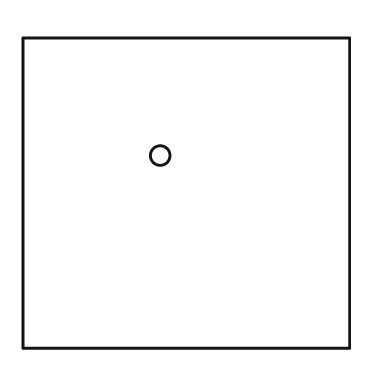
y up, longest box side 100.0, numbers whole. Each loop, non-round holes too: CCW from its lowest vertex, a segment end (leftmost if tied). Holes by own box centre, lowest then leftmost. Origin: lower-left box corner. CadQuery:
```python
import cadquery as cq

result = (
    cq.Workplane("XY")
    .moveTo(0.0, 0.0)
    .lineTo(100.0, 0.0)
    .lineTo(100.0, 95.0)
    .lineTo(0.0, 95.0)
    .close()
    .moveTo(42.0, 59.0)
    .circle(3.0)
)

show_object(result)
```